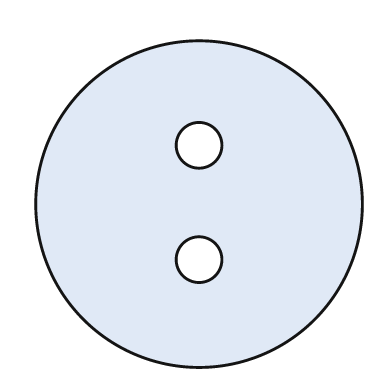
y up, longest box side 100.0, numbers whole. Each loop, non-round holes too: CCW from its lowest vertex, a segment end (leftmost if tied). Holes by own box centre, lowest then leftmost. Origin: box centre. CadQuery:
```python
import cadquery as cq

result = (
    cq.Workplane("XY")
    .moveTo(0.0, 0.0)
    .circle(50.0)
    .moveTo(0.0, -17.0)
    .circle(7.0)
    .moveTo(0.0, 18.0)
    .circle(7.0)
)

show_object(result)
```